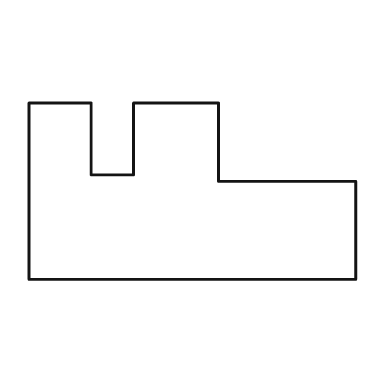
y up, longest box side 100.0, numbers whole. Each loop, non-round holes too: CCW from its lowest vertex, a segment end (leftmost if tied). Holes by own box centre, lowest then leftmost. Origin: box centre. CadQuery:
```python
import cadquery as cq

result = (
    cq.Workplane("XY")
    .moveTo(-50.0, -27.0)
    .lineTo(50.0, -27.0)
    .lineTo(50.0, 3.0)
    .lineTo(8.0, 3.0)
    .lineTo(8.0, 27.0)
    .lineTo(-18.0, 27.0)
    .lineTo(-18.0, 5.0)
    .lineTo(-31.0, 5.0)
    .lineTo(-31.0, 27.0)
    .lineTo(-50.0, 27.0)
    .close()
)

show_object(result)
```